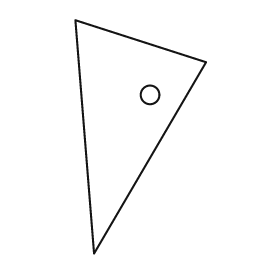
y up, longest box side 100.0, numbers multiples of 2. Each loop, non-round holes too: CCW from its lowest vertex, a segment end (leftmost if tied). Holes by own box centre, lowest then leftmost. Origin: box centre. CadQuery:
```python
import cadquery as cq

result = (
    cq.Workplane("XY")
    .moveTo(-20.0, -50.0)
    .lineTo(28.0, 32.0)
    .lineTo(-28.0, 50.0)
    .close()
    .moveTo(4.0, 18.0)
    .circle(4.0)
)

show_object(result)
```